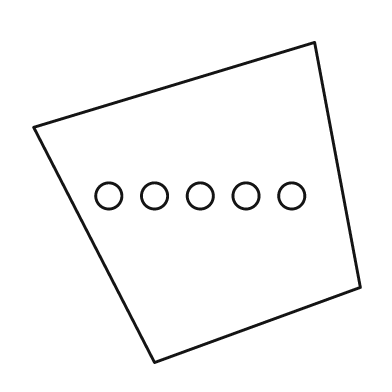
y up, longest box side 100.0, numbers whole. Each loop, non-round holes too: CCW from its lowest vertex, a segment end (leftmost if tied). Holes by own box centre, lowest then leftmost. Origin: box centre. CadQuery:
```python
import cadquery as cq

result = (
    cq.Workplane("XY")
    .moveTo(-13.0, -49.0)
    .lineTo(50.0, -26.0)
    .lineTo(36.0, 49.0)
    .lineTo(-50.0, 23.0)
    .close()
    .moveTo(-27.0, 2.0)
    .circle(4.0)
    .moveTo(-13.0, 2.0)
    .circle(4.0)
    .moveTo(1.0, 2.0)
    .circle(4.0)
    .moveTo(15.0, 2.0)
    .circle(4.0)
    .moveTo(29.0, 2.0)
    .circle(4.0)
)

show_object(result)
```